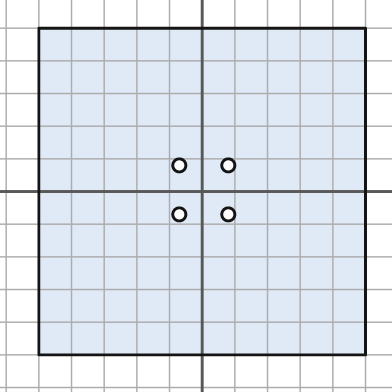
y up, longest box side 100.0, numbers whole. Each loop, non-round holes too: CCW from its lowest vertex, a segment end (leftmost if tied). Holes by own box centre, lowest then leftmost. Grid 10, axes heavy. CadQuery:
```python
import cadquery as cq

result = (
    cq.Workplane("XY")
    .moveTo(-50.0, -50.0)
    .lineTo(50.0, -50.0)
    .lineTo(50.0, 50.0)
    .lineTo(-50.0, 50.0)
    .close()
    .moveTo(-7.0, -7.0)
    .circle(2.0)
    .moveTo(8.0, -7.0)
    .circle(2.0)
    .moveTo(-7.0, 8.0)
    .circle(2.0)
    .moveTo(8.0, 8.0)
    .circle(2.0)
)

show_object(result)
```